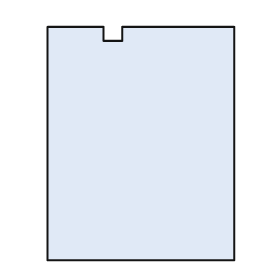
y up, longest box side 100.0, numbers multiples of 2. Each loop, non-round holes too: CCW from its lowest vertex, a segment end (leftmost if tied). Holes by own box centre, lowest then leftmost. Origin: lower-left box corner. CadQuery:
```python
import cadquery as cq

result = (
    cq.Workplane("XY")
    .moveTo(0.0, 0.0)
    .lineTo(80.0, 0.0)
    .lineTo(80.0, 100.0)
    .lineTo(32.0, 100.0)
    .lineTo(32.0, 94.0)
    .lineTo(24.0, 94.0)
    .lineTo(24.0, 100.0)
    .lineTo(0.0, 100.0)
    .close()
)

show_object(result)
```